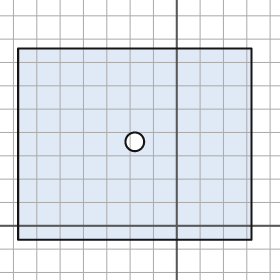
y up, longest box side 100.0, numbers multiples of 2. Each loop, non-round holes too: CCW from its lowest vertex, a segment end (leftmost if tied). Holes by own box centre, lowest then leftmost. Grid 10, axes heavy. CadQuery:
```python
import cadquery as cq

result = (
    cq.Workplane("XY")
    .moveTo(-68.0, -6.0)
    .lineTo(32.0, -6.0)
    .lineTo(32.0, 76.0)
    .lineTo(-68.0, 76.0)
    .close()
    .moveTo(-18.0, 36.0)
    .circle(4.0)
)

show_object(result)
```